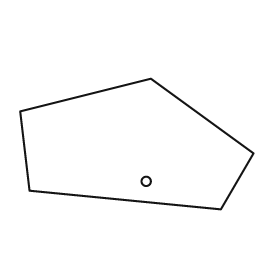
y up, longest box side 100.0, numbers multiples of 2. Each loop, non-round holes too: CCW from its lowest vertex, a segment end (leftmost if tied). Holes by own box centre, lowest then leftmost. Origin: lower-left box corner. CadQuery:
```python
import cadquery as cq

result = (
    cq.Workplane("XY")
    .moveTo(86.0, 0.0)
    .lineTo(100.0, 24.0)
    .lineTo(56.0, 56.0)
    .lineTo(0.0, 42.0)
    .lineTo(4.0, 8.0)
    .close()
    .moveTo(54.0, 12.0)
    .circle(2.0)
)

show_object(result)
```